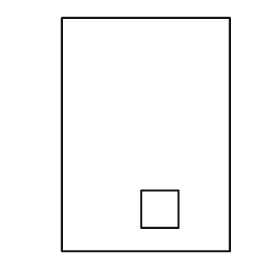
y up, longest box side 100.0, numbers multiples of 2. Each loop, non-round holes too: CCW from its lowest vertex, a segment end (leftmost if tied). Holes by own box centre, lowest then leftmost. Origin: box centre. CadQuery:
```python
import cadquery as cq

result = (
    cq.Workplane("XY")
    .moveTo(-36.0, -50.0)
    .lineTo(36.0, -50.0)
    .lineTo(36.0, 50.0)
    .lineTo(-36.0, 50.0)
    .close()
    .moveTo(-2.0, -40.0)
    .lineTo(14.0, -40.0)
    .lineTo(14.0, -24.0)
    .lineTo(-2.0, -24.0)
    .close()
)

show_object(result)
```